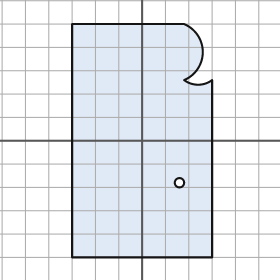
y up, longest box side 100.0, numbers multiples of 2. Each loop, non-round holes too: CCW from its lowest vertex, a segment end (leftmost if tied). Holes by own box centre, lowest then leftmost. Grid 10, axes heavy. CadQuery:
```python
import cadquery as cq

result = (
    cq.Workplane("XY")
    .moveTo(-30.0, -50.0)
    .lineTo(30.0, -50.0)
    .lineTo(30.0, 26.0)
    .threePointArc((24.0, 24.0), (18.0, 26.0))
    .threePointArc((26.0, 38.0), (18.0, 50.0))
    .lineTo(-30.0, 50.0)
    .close()
    .moveTo(16.0, -18.0)
    .circle(2.0)
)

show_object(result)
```